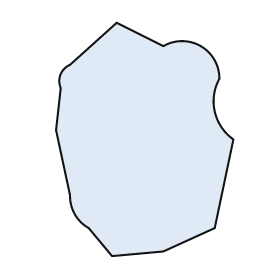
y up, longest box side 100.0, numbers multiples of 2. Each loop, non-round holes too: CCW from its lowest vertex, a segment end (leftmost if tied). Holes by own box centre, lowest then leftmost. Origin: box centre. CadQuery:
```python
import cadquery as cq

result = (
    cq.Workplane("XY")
    .moveTo(-14.0, -50.0)
    .lineTo(8.0, -48.0)
    .lineTo(30.0, -38.0)
    .lineTo(38.0, 0.0)
    .threePointArc((30.0, 12.0), (32.0, 26.0))
    .threePointArc((24.0, 40.0), (8.0, 40.0))
    .lineTo(-12.0, 50.0)
    .lineTo(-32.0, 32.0)
    .threePointArc((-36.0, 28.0), (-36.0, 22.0))
    .lineTo(-38.0, 4.0)
    .lineTo(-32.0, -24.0)
    .threePointArc((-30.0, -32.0), (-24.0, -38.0))
    .close()
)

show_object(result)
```